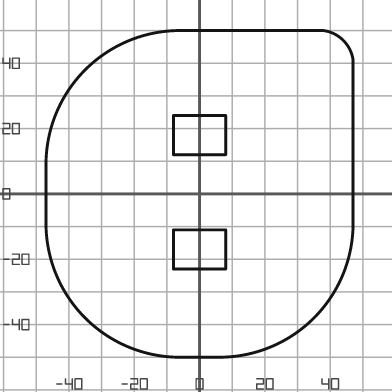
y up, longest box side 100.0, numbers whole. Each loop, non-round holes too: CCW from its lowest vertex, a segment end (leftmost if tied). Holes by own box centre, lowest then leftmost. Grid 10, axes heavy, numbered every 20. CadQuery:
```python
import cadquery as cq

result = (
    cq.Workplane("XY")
    .moveTo(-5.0, -50.0)
    .lineTo(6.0, -50.0)
    .threePointArc((35.0, -38.0), (47.0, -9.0))
    .lineTo(47.0, 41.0)
    .threePointArc((44.0, 47.0), (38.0, 50.0))
    .lineTo(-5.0, 50.0)
    .threePointArc((-35.0, 38.0), (-47.0, 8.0))
    .lineTo(-47.0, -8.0)
    .threePointArc((-35.0, -38.0), (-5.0, -50.0))
    .close()
    .moveTo(-8.0, -23.0)
    .lineTo(8.0, -23.0)
    .lineTo(8.0, -11.0)
    .lineTo(-8.0, -11.0)
    .close()
    .moveTo(-8.0, 12.0)
    .lineTo(8.0, 12.0)
    .lineTo(8.0, 24.0)
    .lineTo(-8.0, 24.0)
    .close()
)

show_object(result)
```